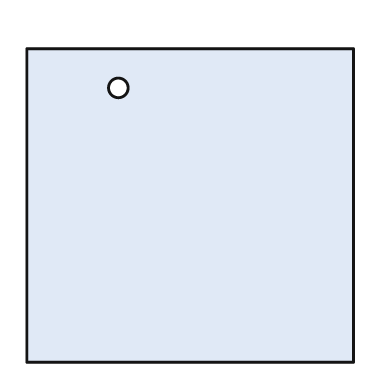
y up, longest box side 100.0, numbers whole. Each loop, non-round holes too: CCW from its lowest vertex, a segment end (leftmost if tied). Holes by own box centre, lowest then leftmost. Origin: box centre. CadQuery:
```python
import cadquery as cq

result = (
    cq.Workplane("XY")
    .moveTo(-50.0, -48.0)
    .lineTo(50.0, -48.0)
    .lineTo(50.0, 48.0)
    .lineTo(-50.0, 48.0)
    .close()
    .moveTo(-22.0, 36.0)
    .circle(3.0)
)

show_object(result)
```